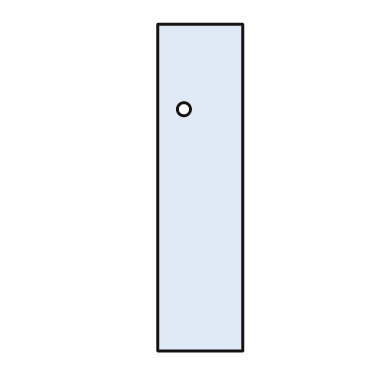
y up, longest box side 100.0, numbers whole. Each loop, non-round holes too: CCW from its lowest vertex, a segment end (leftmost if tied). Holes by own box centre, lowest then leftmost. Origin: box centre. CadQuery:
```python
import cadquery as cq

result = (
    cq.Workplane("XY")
    .moveTo(-13.0, -50.0)
    .lineTo(13.0, -50.0)
    .lineTo(13.0, 50.0)
    .lineTo(-13.0, 50.0)
    .close()
    .moveTo(-5.0, 24.0)
    .circle(2.0)
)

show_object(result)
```